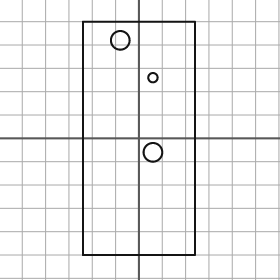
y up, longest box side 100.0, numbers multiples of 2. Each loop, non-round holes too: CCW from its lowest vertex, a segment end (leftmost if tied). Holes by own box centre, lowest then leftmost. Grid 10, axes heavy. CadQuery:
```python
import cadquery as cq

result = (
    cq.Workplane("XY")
    .moveTo(-24.0, -50.0)
    .lineTo(24.0, -50.0)
    .lineTo(24.0, 50.0)
    .lineTo(-24.0, 50.0)
    .close()
    .moveTo(6.0, -6.0)
    .circle(4.0)
    .moveTo(6.0, 26.0)
    .circle(2.0)
    .moveTo(-8.0, 42.0)
    .circle(4.0)
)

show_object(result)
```